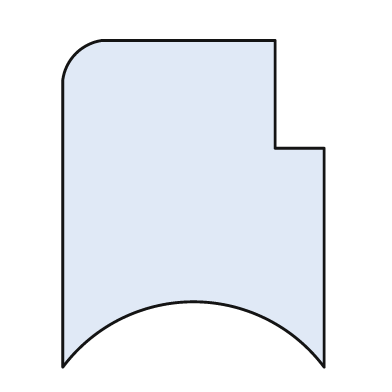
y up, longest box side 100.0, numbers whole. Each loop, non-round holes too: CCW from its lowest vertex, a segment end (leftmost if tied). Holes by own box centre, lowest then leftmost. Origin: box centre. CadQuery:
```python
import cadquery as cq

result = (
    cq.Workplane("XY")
    .moveTo(-40.0, -50.0)
    .threePointArc((0.0, -30.0), (40.0, -50.0))
    .lineTo(40.0, 17.0)
    .lineTo(25.0, 17.0)
    .lineTo(25.0, 50.0)
    .lineTo(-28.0, 50.0)
    .threePointArc((-36.0, 46.0), (-40.0, 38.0))
    .close()
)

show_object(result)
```